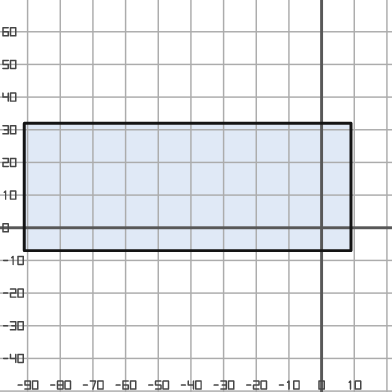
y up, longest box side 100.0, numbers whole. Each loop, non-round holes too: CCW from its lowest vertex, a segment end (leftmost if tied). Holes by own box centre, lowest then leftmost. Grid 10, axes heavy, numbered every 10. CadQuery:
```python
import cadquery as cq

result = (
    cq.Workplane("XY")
    .moveTo(-91.0, -7.0)
    .lineTo(9.0, -7.0)
    .lineTo(9.0, 32.0)
    .lineTo(-91.0, 32.0)
    .close()
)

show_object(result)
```